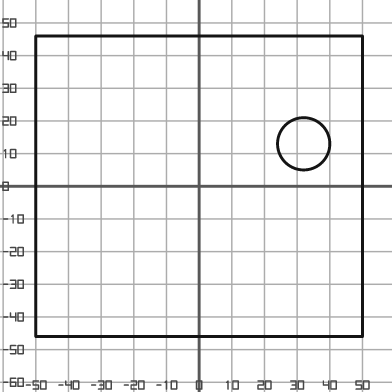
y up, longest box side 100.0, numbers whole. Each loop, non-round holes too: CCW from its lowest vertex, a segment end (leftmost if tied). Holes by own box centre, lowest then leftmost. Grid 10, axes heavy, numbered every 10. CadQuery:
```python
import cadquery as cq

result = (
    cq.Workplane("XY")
    .moveTo(-50.0, -46.0)
    .lineTo(50.0, -46.0)
    .lineTo(50.0, 46.0)
    .lineTo(-50.0, 46.0)
    .close()
    .moveTo(32.0, 13.0)
    .circle(8.0)
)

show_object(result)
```